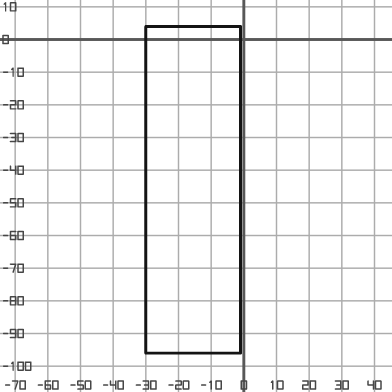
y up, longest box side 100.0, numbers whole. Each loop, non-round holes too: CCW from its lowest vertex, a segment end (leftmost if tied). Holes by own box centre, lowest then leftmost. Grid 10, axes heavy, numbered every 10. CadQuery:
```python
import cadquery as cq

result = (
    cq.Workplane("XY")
    .moveTo(-30.0, -96.0)
    .lineTo(-1.0, -96.0)
    .lineTo(-1.0, 4.0)
    .lineTo(-30.0, 4.0)
    .close()
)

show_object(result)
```